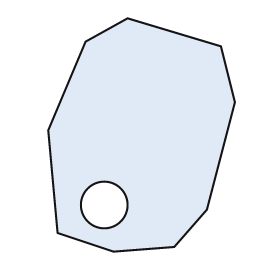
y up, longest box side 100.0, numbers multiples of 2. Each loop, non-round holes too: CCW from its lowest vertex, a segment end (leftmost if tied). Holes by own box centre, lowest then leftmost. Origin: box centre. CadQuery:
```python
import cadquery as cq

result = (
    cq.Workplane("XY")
    .moveTo(-12.0, -50.0)
    .lineTo(14.0, -48.0)
    .lineTo(28.0, -32.0)
    .lineTo(40.0, 14.0)
    .lineTo(34.0, 38.0)
    .lineTo(-6.0, 50.0)
    .lineTo(-24.0, 40.0)
    .lineTo(-40.0, 2.0)
    .lineTo(-36.0, -42.0)
    .close()
    .moveTo(-16.0, -30.0)
    .circle(10.0)
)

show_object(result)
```